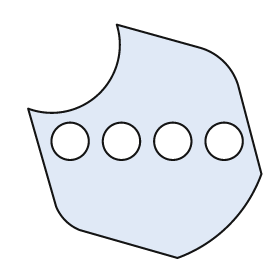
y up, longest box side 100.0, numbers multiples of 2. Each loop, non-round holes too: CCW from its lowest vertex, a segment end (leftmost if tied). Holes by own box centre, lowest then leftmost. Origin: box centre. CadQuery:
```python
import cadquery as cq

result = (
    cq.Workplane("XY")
    .moveTo(14.0, -50.0)
    .threePointArc((36.0, -36.0), (50.0, -14.0))
    .lineTo(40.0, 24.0)
    .threePointArc((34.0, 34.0), (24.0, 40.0))
    .lineTo(-12.0, 50.0)
    .threePointArc((-20.0, 20.0), (-50.0, 14.0))
    .lineTo(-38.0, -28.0)
    .threePointArc((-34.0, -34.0), (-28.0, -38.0))
    .close()
    .moveTo(-32.0, 0.0)
    .circle(8.0)
    .moveTo(-10.0, 0.0)
    .circle(8.0)
    .moveTo(12.0, 0.0)
    .circle(8.0)
    .moveTo(34.0, 0.0)
    .circle(8.0)
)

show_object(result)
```